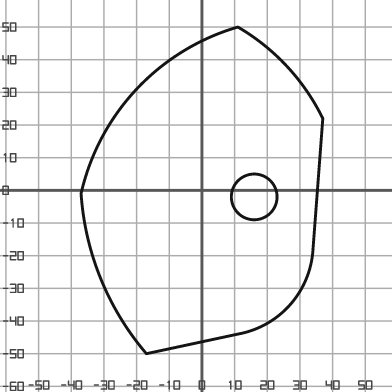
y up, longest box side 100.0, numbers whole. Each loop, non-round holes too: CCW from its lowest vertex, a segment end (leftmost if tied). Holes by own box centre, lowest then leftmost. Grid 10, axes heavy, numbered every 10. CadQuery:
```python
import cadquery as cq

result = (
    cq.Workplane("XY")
    .moveTo(-17.0, -50.0)
    .lineTo(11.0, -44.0)
    .threePointArc((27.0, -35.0), (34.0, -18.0))
    .lineTo(37.0, 22.0)
    .threePointArc((26.0, 38.0), (11.0, 50.0))
    .threePointArc((-20.0, 31.0), (-37.0, -1.0))
    .threePointArc((-31.0, -27.0), (-17.0, -50.0))
    .close()
    .moveTo(16.0, -2.0)
    .circle(7.0)
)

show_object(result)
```